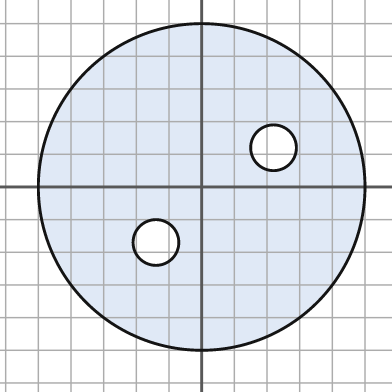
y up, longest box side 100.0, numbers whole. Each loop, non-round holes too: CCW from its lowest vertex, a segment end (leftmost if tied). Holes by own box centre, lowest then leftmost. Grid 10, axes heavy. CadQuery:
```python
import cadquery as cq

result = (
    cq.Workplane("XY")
    .moveTo(0.0, 0.0)
    .circle(50.0)
    .moveTo(-14.0, -17.0)
    .circle(7.0)
    .moveTo(22.0, 12.0)
    .circle(7.0)
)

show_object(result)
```